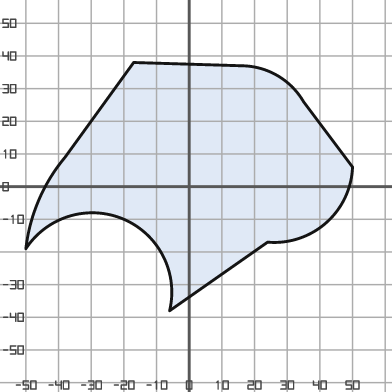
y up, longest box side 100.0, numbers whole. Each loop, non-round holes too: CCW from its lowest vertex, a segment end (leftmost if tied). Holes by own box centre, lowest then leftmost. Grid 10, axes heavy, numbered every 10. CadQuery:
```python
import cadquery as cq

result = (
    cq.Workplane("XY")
    .moveTo(-6.0, -38.0)
    .lineTo(24.0, -17.0)
    .threePointArc((42.0, -11.0), (50.0, 6.0))
    .lineTo(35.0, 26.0)
    .threePointArc((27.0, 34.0), (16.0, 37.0))
    .lineTo(-17.0, 38.0)
    .lineTo(-38.0, 9.0)
    .threePointArc((-46.0, -4.0), (-50.0, -19.0))
    .threePointArc((-20.0, -10.0), (-6.0, -38.0))
    .close()
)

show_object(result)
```